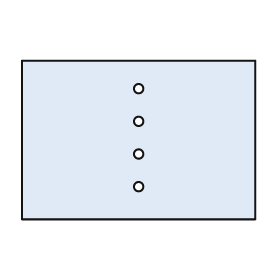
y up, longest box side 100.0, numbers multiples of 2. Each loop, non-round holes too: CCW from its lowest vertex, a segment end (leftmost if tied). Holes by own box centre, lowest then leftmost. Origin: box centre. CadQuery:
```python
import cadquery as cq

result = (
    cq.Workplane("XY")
    .moveTo(-50.0, -34.0)
    .lineTo(50.0, -34.0)
    .lineTo(50.0, 34.0)
    .lineTo(-50.0, 34.0)
    .close()
    .moveTo(0.0, -20.0)
    .circle(2.0)
    .moveTo(0.0, -6.0)
    .circle(2.0)
    .moveTo(0.0, 8.0)
    .circle(2.0)
    .moveTo(0.0, 22.0)
    .circle(2.0)
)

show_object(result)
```